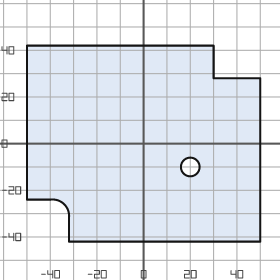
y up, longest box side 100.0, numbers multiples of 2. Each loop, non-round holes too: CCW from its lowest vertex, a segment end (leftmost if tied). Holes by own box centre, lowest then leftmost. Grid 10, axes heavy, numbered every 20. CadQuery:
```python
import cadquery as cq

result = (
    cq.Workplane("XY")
    .moveTo(-32.0, -42.0)
    .lineTo(50.0, -42.0)
    .lineTo(50.0, 28.0)
    .lineTo(30.0, 28.0)
    .lineTo(30.0, 42.0)
    .lineTo(-50.0, 42.0)
    .lineTo(-50.0, -24.0)
    .lineTo(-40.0, -24.0)
    .threePointArc((-34.0, -26.0), (-32.0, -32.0))
    .close()
    .moveTo(20.0, -10.0)
    .circle(4.0)
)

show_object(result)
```